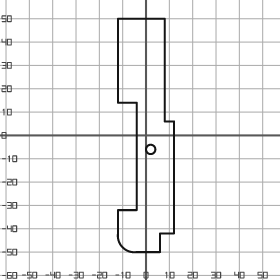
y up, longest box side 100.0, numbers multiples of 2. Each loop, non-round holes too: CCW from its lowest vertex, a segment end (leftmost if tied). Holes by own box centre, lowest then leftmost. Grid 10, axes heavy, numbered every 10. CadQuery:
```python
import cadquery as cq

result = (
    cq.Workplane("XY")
    .moveTo(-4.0, -50.0)
    .lineTo(6.0, -50.0)
    .lineTo(6.0, -42.0)
    .lineTo(12.0, -42.0)
    .lineTo(12.0, 6.0)
    .lineTo(8.0, 6.0)
    .lineTo(8.0, 50.0)
    .lineTo(-12.0, 50.0)
    .lineTo(-12.0, 14.0)
    .lineTo(-4.0, 14.0)
    .lineTo(-4.0, -32.0)
    .lineTo(-12.0, -32.0)
    .lineTo(-12.0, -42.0)
    .threePointArc((-10.0, -48.0), (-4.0, -50.0))
    .close()
    .moveTo(2.0, -6.0)
    .circle(2.0)
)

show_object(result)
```